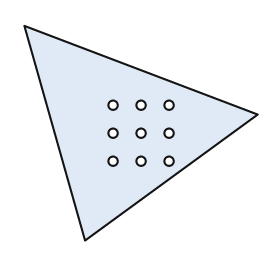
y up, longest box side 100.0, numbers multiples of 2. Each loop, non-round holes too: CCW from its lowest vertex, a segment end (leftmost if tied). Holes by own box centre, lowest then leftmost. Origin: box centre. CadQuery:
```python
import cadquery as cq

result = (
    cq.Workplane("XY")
    .moveTo(-24.0, -46.0)
    .lineTo(50.0, 8.0)
    .lineTo(-50.0, 46.0)
    .close()
    .moveTo(-12.0, -12.0)
    .circle(2.0)
    .moveTo(0.0, -12.0)
    .circle(2.0)
    .moveTo(12.0, -12.0)
    .circle(2.0)
    .moveTo(-12.0, 0.0)
    .circle(2.0)
    .moveTo(0.0, 0.0)
    .circle(2.0)
    .moveTo(12.0, 0.0)
    .circle(2.0)
    .moveTo(-12.0, 12.0)
    .circle(2.0)
    .moveTo(0.0, 12.0)
    .circle(2.0)
    .moveTo(12.0, 12.0)
    .circle(2.0)
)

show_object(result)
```